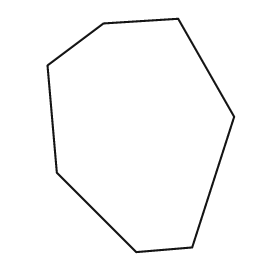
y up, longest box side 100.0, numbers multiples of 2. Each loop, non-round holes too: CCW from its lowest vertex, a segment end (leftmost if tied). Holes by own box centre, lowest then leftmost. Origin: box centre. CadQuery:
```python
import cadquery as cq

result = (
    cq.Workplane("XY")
    .moveTo(-2.0, -50.0)
    .lineTo(22.0, -48.0)
    .lineTo(40.0, 8.0)
    .lineTo(16.0, 50.0)
    .lineTo(-16.0, 48.0)
    .lineTo(-40.0, 30.0)
    .lineTo(-36.0, -16.0)
    .close()
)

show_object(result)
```